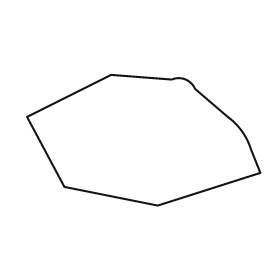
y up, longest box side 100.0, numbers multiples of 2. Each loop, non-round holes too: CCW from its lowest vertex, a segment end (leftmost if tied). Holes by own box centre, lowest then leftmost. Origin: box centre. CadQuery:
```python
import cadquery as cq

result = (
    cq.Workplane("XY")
    .moveTo(6.0, -28.0)
    .lineTo(50.0, -14.0)
    .lineTo(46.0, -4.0)
    .threePointArc((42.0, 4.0), (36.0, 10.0))
    .lineTo(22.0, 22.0)
    .threePointArc((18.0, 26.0), (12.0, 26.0))
    .lineTo(-14.0, 28.0)
    .lineTo(-50.0, 10.0)
    .lineTo(-34.0, -20.0)
    .close()
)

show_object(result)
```